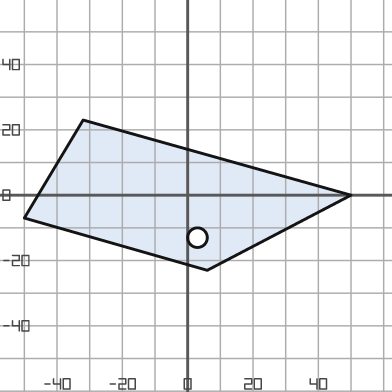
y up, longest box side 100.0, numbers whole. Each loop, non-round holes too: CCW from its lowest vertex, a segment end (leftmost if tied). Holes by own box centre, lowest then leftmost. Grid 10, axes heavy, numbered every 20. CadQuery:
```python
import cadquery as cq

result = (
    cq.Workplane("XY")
    .moveTo(6.0, -23.0)
    .lineTo(50.0, 0.0)
    .lineTo(-32.0, 23.0)
    .lineTo(-50.0, -7.0)
    .close()
    .moveTo(3.0, -13.0)
    .circle(3.0)
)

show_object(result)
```